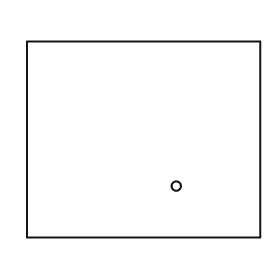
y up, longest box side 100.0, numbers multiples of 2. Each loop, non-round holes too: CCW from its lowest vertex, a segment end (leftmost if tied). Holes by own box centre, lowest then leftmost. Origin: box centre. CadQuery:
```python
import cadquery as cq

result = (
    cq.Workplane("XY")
    .moveTo(-50.0, -42.0)
    .lineTo(50.0, -42.0)
    .lineTo(50.0, 42.0)
    .lineTo(-50.0, 42.0)
    .close()
    .moveTo(14.0, -20.0)
    .circle(2.0)
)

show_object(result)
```